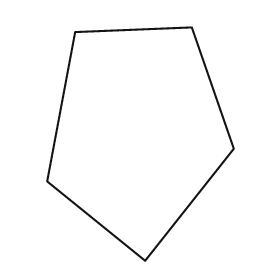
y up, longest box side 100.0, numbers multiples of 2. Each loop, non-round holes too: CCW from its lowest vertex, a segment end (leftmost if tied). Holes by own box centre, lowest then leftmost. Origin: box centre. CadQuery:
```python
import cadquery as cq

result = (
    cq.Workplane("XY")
    .moveTo(2.0, -50.0)
    .lineTo(40.0, -2.0)
    .lineTo(22.0, 50.0)
    .lineTo(-28.0, 48.0)
    .lineTo(-40.0, -16.0)
    .close()
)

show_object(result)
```